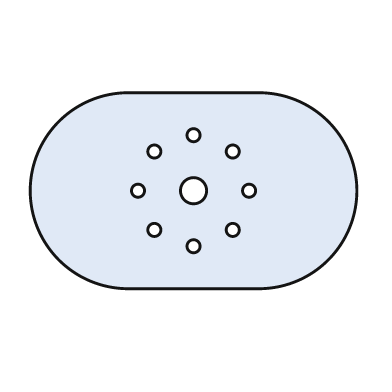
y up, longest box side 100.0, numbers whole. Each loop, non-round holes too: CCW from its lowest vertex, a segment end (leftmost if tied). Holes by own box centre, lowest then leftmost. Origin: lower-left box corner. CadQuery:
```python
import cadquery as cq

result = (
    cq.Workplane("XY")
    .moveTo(30.0, 0.0)
    .lineTo(70.0, 0.0)
    .threePointArc((100.0, 30.0), (70.0, 60.0))
    .lineTo(30.0, 60.0)
    .threePointArc((0.0, 30.0), (30.0, 0.0))
    .close()
    .moveTo(50.0, 13.0)
    .circle(2.0)
    .moveTo(38.0, 18.0)
    .circle(2.0)
    .moveTo(62.0, 18.0)
    .circle(2.0)
    .moveTo(33.0, 30.0)
    .circle(2.0)
    .moveTo(50.0, 30.0)
    .circle(4.0)
    .moveTo(67.0, 30.0)
    .circle(2.0)
    .moveTo(38.0, 42.0)
    .circle(2.0)
    .moveTo(62.0, 42.0)
    .circle(2.0)
    .moveTo(50.0, 47.0)
    .circle(2.0)
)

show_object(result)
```